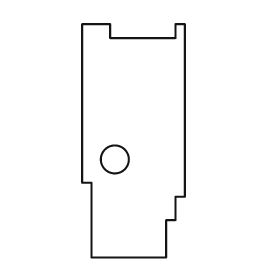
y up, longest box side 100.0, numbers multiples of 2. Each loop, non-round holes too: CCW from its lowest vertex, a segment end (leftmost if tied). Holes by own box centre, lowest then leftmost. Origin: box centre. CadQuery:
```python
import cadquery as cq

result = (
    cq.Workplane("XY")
    .moveTo(-18.0, -50.0)
    .lineTo(14.0, -50.0)
    .lineTo(14.0, -34.0)
    .lineTo(18.0, -34.0)
    .lineTo(18.0, -24.0)
    .lineTo(22.0, -24.0)
    .lineTo(22.0, 50.0)
    .lineTo(18.0, 50.0)
    .lineTo(18.0, 44.0)
    .lineTo(-10.0, 44.0)
    .lineTo(-10.0, 50.0)
    .lineTo(-22.0, 50.0)
    .lineTo(-22.0, -18.0)
    .lineTo(-18.0, -18.0)
    .close()
    .moveTo(-8.0, -8.0)
    .circle(6.0)
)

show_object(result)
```